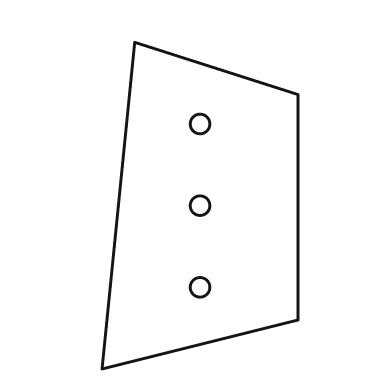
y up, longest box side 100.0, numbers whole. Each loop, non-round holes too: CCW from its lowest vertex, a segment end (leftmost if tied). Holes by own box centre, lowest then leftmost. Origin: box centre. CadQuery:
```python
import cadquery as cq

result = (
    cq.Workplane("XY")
    .moveTo(-30.0, -50.0)
    .lineTo(30.0, -35.0)
    .lineTo(30.0, 34.0)
    .lineTo(-20.0, 50.0)
    .close()
    .moveTo(0.0, -25.0)
    .circle(3.0)
    .moveTo(0.0, 0.0)
    .circle(3.0)
    .moveTo(0.0, 25.0)
    .circle(3.0)
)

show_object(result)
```